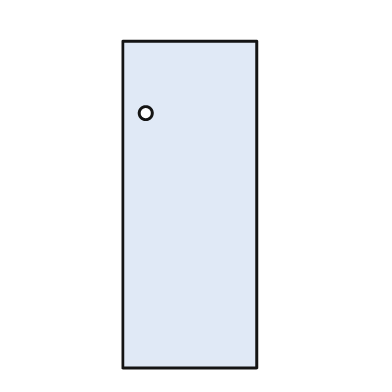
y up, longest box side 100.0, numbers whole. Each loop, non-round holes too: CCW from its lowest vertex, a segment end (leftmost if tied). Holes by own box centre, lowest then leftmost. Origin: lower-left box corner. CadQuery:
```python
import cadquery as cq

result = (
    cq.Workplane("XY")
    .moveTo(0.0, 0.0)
    .lineTo(41.0, 0.0)
    .lineTo(41.0, 100.0)
    .lineTo(0.0, 100.0)
    .close()
    .moveTo(7.0, 78.0)
    .circle(2.0)
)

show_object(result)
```